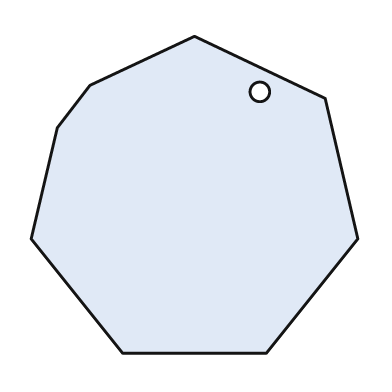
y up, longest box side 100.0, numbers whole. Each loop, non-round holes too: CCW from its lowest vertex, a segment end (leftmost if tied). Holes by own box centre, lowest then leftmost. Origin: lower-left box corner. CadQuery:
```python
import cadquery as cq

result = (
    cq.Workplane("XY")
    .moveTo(28.0, 0.0)
    .lineTo(72.0, 0.0)
    .lineTo(100.0, 35.0)
    .lineTo(90.0, 78.0)
    .lineTo(50.0, 97.0)
    .lineTo(18.0, 82.0)
    .lineTo(8.0, 69.0)
    .lineTo(0.0, 35.0)
    .close()
    .moveTo(70.0, 80.0)
    .circle(3.0)
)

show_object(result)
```